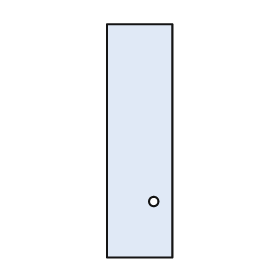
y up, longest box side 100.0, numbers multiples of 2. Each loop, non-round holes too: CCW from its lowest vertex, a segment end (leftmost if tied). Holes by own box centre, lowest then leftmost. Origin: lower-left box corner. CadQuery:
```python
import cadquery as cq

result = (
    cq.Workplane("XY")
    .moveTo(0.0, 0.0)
    .lineTo(28.0, 0.0)
    .lineTo(28.0, 100.0)
    .lineTo(0.0, 100.0)
    .close()
    .moveTo(20.0, 24.0)
    .circle(2.0)
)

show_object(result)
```